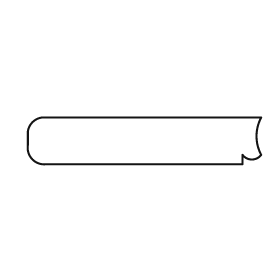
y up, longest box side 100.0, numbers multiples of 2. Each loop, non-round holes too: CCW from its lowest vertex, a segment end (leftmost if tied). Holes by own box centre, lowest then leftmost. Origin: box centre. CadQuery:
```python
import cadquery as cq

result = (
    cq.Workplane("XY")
    .moveTo(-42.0, -10.0)
    .lineTo(42.0, -10.0)
    .lineTo(42.0, -6.0)
    .threePointArc((46.0, -8.0), (50.0, -6.0))
    .threePointArc((48.0, 2.0), (50.0, 10.0))
    .lineTo(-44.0, 10.0)
    .threePointArc((-48.0, 8.0), (-50.0, 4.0))
    .lineTo(-50.0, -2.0)
    .threePointArc((-48.0, -8.0), (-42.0, -10.0))
    .close()
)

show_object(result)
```